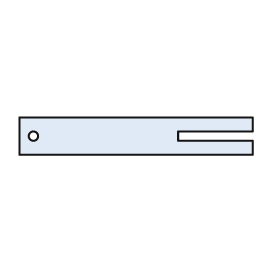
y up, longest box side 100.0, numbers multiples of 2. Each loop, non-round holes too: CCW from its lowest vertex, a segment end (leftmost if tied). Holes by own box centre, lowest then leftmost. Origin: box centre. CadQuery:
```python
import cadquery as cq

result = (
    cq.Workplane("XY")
    .moveTo(-50.0, -8.0)
    .lineTo(50.0, -8.0)
    .lineTo(50.0, -2.0)
    .lineTo(18.0, -2.0)
    .lineTo(18.0, 2.0)
    .lineTo(50.0, 2.0)
    .lineTo(50.0, 8.0)
    .lineTo(-50.0, 8.0)
    .close()
    .moveTo(-44.0, 0.0)
    .circle(2.0)
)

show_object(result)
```